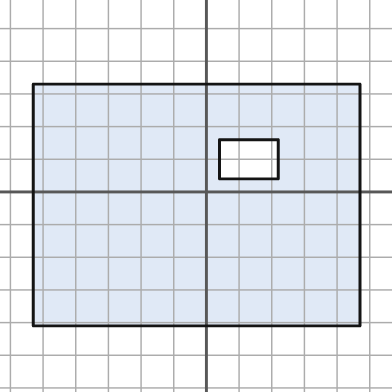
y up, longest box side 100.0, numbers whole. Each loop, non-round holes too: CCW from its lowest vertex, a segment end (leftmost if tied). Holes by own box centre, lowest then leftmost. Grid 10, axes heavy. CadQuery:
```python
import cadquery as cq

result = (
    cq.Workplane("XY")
    .moveTo(-53.0, -41.0)
    .lineTo(47.0, -41.0)
    .lineTo(47.0, 33.0)
    .lineTo(-53.0, 33.0)
    .close()
    .moveTo(4.0, 4.0)
    .lineTo(22.0, 4.0)
    .lineTo(22.0, 16.0)
    .lineTo(4.0, 16.0)
    .close()
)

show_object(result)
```